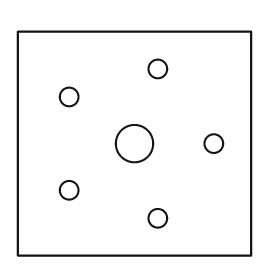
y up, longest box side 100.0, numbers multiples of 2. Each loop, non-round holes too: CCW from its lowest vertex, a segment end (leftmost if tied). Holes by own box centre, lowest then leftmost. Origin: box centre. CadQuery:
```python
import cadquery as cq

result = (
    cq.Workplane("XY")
    .moveTo(-50.0, -48.0)
    .lineTo(50.0, -48.0)
    .lineTo(50.0, 48.0)
    .lineTo(-50.0, 48.0)
    .close()
    .moveTo(10.0, -32.0)
    .circle(4.0)
    .moveTo(-28.0, -20.0)
    .circle(4.0)
    .moveTo(0.0, 0.0)
    .circle(8.0)
    .moveTo(34.0, 0.0)
    .circle(4.0)
    .moveTo(-28.0, 20.0)
    .circle(4.0)
    .moveTo(10.0, 32.0)
    .circle(4.0)
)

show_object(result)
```